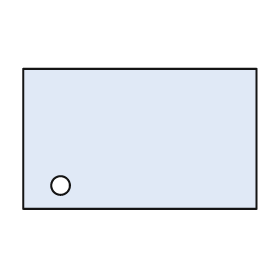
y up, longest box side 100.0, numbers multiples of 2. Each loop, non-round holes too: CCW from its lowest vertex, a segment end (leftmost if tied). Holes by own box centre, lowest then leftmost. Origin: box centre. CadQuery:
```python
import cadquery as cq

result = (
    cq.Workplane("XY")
    .moveTo(-50.0, -30.0)
    .lineTo(50.0, -30.0)
    .lineTo(50.0, 30.0)
    .lineTo(-50.0, 30.0)
    .close()
    .moveTo(-34.0, -20.0)
    .circle(4.0)
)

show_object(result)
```